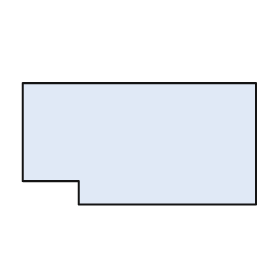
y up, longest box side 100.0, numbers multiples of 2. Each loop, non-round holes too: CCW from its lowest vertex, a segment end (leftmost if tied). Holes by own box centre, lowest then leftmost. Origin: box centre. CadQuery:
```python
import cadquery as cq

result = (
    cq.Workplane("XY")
    .moveTo(-26.0, -26.0)
    .lineTo(50.0, -26.0)
    .lineTo(50.0, 26.0)
    .lineTo(-50.0, 26.0)
    .lineTo(-50.0, -16.0)
    .lineTo(-26.0, -16.0)
    .close()
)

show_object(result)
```